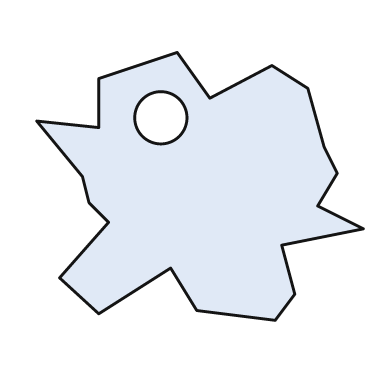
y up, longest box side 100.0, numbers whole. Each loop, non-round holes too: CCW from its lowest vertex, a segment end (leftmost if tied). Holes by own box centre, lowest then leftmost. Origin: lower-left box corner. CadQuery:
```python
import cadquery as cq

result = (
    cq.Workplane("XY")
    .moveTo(73.0, 0.0)
    .lineTo(79.0, 8.0)
    .lineTo(75.0, 23.0)
    .lineTo(100.0, 28.0)
    .lineTo(86.0, 35.0)
    .lineTo(92.0, 45.0)
    .lineTo(88.0, 53.0)
    .lineTo(83.0, 71.0)
    .lineTo(72.0, 78.0)
    .lineTo(53.0, 68.0)
    .lineTo(43.0, 82.0)
    .lineTo(19.0, 74.0)
    .lineTo(19.0, 59.0)
    .lineTo(0.0, 61.0)
    .lineTo(14.0, 44.0)
    .lineTo(16.0, 36.0)
    .lineTo(22.0, 30.0)
    .lineTo(7.0, 13.0)
    .lineTo(19.0, 2.0)
    .lineTo(41.0, 16.0)
    .lineTo(49.0, 3.0)
    .close()
    .moveTo(38.0, 62.0)
    .circle(8.0)
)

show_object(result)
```